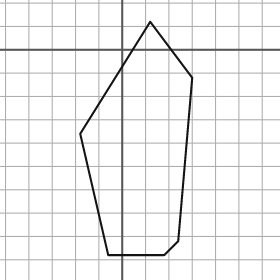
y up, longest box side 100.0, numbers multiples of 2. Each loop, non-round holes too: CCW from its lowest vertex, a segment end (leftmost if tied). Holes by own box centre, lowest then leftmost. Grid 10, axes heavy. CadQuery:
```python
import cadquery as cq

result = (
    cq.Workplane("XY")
    .moveTo(-6.0, -88.0)
    .lineTo(18.0, -88.0)
    .lineTo(24.0, -82.0)
    .lineTo(30.0, -12.0)
    .lineTo(12.0, 12.0)
    .lineTo(-18.0, -36.0)
    .close()
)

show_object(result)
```